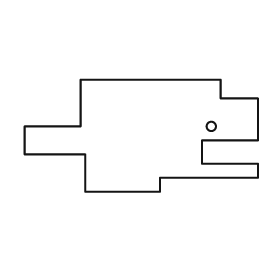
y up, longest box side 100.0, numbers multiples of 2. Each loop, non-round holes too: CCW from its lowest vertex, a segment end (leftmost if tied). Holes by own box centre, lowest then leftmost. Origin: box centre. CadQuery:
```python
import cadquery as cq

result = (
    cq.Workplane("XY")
    .moveTo(-24.0, -24.0)
    .lineTo(8.0, -24.0)
    .lineTo(8.0, -18.0)
    .lineTo(50.0, -18.0)
    .lineTo(50.0, -12.0)
    .lineTo(26.0, -12.0)
    .lineTo(26.0, -2.0)
    .lineTo(50.0, -2.0)
    .lineTo(50.0, 16.0)
    .lineTo(34.0, 16.0)
    .lineTo(34.0, 24.0)
    .lineTo(-26.0, 24.0)
    .lineTo(-26.0, 4.0)
    .lineTo(-50.0, 4.0)
    .lineTo(-50.0, -8.0)
    .lineTo(-24.0, -8.0)
    .close()
    .moveTo(30.0, 4.0)
    .circle(2.0)
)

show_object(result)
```